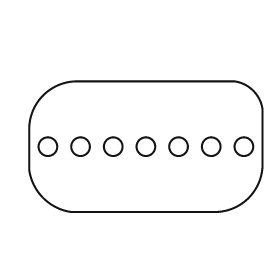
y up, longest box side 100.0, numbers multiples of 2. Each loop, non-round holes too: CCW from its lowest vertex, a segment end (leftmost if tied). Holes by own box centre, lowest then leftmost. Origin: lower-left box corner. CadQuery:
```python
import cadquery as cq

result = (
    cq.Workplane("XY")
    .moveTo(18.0, 0.0)
    .lineTo(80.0, 0.0)
    .threePointArc((94.0, 6.0), (100.0, 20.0))
    .lineTo(100.0, 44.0)
    .threePointArc((96.0, 52.0), (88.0, 56.0))
    .lineTo(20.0, 56.0)
    .threePointArc((6.0, 50.0), (0.0, 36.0))
    .lineTo(0.0, 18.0)
    .threePointArc((6.0, 6.0), (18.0, 0.0))
    .close()
    .moveTo(8.0, 28.0)
    .circle(4.0)
    .moveTo(22.0, 28.0)
    .circle(4.0)
    .moveTo(36.0, 28.0)
    .circle(4.0)
    .moveTo(50.0, 28.0)
    .circle(4.0)
    .moveTo(64.0, 28.0)
    .circle(4.0)
    .moveTo(78.0, 28.0)
    .circle(4.0)
    .moveTo(92.0, 28.0)
    .circle(4.0)
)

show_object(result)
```